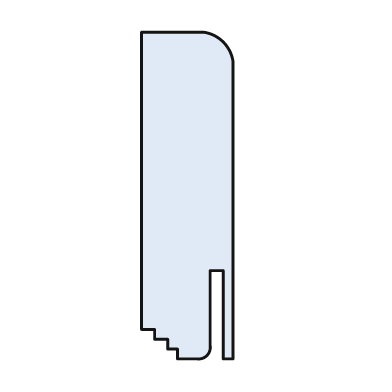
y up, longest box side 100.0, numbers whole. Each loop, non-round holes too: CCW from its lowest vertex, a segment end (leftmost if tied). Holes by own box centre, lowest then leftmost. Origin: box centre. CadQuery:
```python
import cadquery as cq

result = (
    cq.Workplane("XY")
    .moveTo(-3.0, -50.0)
    .lineTo(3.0, -50.0)
    .threePointArc((6.0, -49.0), (7.0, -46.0))
    .lineTo(7.0, -23.0)
    .lineTo(11.0, -23.0)
    .lineTo(11.0, -50.0)
    .lineTo(14.0, -50.0)
    .lineTo(14.0, 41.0)
    .threePointArc((11.0, 47.0), (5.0, 50.0))
    .lineTo(-14.0, 50.0)
    .lineTo(-14.0, -41.0)
    .lineTo(-10.0, -41.0)
    .lineTo(-10.0, -44.0)
    .lineTo(-6.0, -44.0)
    .lineTo(-6.0, -47.0)
    .lineTo(-3.0, -47.0)
    .close()
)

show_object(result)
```